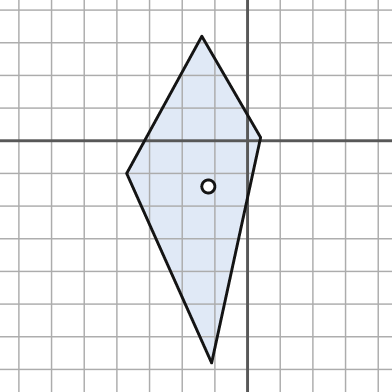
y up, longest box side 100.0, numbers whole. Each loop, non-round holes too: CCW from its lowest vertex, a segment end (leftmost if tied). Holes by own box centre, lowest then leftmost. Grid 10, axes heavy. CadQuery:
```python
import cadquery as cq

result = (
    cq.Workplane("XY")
    .moveTo(-11.0, -68.0)
    .lineTo(4.0, 1.0)
    .lineTo(-14.0, 32.0)
    .lineTo(-37.0, -10.0)
    .close()
    .moveTo(-12.0, -14.0)
    .circle(2.0)
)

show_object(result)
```